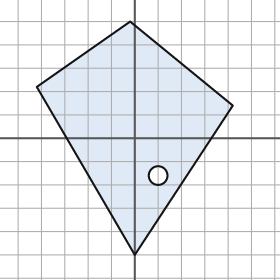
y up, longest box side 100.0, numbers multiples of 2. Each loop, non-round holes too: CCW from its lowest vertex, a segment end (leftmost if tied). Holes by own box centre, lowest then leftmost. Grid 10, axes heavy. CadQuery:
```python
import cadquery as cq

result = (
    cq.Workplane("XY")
    .moveTo(0.0, -50.0)
    .lineTo(42.0, 14.0)
    .lineTo(-2.0, 50.0)
    .lineTo(-42.0, 22.0)
    .close()
    .moveTo(10.0, -16.0)
    .circle(4.0)
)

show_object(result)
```